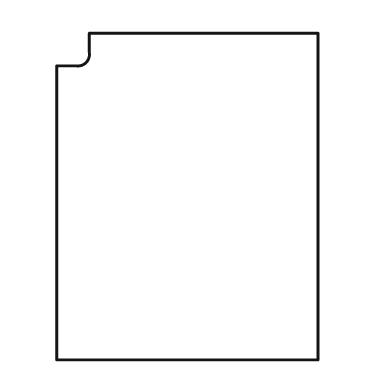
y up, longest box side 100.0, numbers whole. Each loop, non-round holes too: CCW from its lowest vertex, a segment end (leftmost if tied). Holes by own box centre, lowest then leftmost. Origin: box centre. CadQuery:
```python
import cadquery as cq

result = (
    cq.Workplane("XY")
    .moveTo(-40.0, -50.0)
    .lineTo(40.0, -50.0)
    .lineTo(40.0, 50.0)
    .lineTo(-30.0, 50.0)
    .lineTo(-30.0, 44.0)
    .threePointArc((-31.0, 41.0), (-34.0, 40.0))
    .lineTo(-40.0, 40.0)
    .close()
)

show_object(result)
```